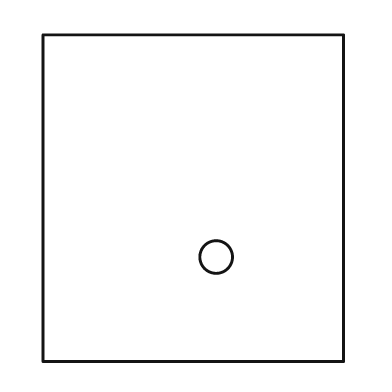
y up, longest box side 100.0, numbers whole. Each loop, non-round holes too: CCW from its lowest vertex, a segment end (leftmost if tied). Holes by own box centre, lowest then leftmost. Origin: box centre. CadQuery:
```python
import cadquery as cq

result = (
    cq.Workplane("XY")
    .moveTo(-46.0, -50.0)
    .lineTo(46.0, -50.0)
    .lineTo(46.0, 50.0)
    .lineTo(-46.0, 50.0)
    .close()
    .moveTo(7.0, -18.0)
    .circle(5.0)
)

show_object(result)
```